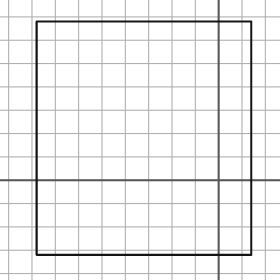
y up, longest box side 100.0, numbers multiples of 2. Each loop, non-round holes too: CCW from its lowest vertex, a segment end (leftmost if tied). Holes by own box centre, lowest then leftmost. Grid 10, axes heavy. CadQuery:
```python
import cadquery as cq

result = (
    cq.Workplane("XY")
    .moveTo(-78.0, -32.0)
    .lineTo(14.0, -32.0)
    .lineTo(14.0, 68.0)
    .lineTo(-78.0, 68.0)
    .close()
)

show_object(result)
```